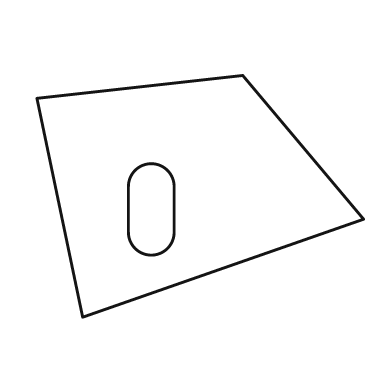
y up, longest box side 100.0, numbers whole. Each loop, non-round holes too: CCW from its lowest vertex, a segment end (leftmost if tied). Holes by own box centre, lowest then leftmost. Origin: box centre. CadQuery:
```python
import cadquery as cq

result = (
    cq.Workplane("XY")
    .moveTo(-36.0, -37.0)
    .lineTo(50.0, -7.0)
    .lineTo(13.0, 37.0)
    .lineTo(-50.0, 30.0)
    .close()
    .moveTo(-22.0, -11.0)
    .threePointArc((-15.0, -18.0), (-8.0, -11.0))
    .lineTo(-8.0, 3.0)
    .threePointArc((-15.0, 10.0), (-22.0, 3.0))
    .close()
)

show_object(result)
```